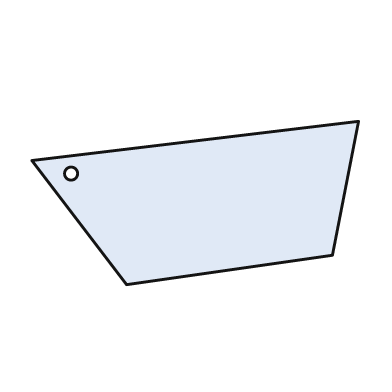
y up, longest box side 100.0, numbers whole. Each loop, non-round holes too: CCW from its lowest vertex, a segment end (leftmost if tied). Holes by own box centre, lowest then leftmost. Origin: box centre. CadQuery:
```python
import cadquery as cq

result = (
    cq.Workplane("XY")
    .moveTo(-21.0, -25.0)
    .lineTo(42.0, -16.0)
    .lineTo(50.0, 25.0)
    .lineTo(-50.0, 13.0)
    .close()
    .moveTo(-38.0, 9.0)
    .circle(2.0)
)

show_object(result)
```